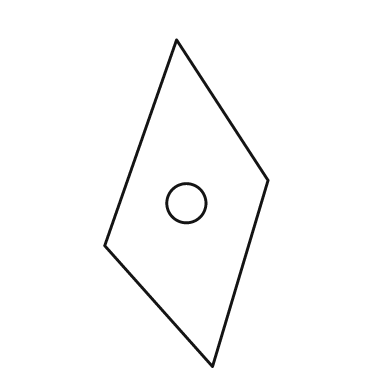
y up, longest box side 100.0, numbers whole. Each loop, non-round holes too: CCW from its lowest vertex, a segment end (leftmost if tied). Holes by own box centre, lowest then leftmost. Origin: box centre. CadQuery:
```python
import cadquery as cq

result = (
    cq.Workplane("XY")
    .moveTo(8.0, -50.0)
    .lineTo(25.0, 7.0)
    .lineTo(-3.0, 50.0)
    .lineTo(-25.0, -13.0)
    .close()
    .moveTo(0.0, 0.0)
    .circle(6.0)
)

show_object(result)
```